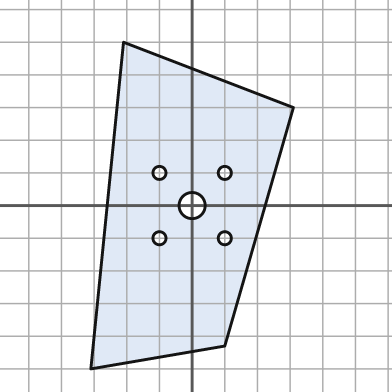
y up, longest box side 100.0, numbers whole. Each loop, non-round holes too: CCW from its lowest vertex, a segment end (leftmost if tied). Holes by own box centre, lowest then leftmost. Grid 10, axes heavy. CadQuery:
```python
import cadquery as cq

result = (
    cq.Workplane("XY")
    .moveTo(-31.0, -50.0)
    .lineTo(10.0, -43.0)
    .lineTo(31.0, 30.0)
    .lineTo(-21.0, 50.0)
    .close()
    .moveTo(-10.0, -10.0)
    .circle(2.0)
    .moveTo(10.0, -10.0)
    .circle(2.0)
    .moveTo(0.0, 0.0)
    .circle(4.0)
    .moveTo(-10.0, 10.0)
    .circle(2.0)
    .moveTo(10.0, 10.0)
    .circle(2.0)
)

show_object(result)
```